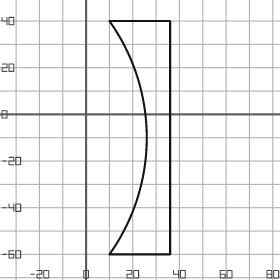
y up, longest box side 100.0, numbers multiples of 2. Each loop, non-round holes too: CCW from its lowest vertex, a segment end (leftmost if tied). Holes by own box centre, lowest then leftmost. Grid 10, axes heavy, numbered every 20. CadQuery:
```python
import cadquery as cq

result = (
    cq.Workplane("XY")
    .moveTo(10.0, -60.0)
    .lineTo(36.0, -60.0)
    .lineTo(36.0, 40.0)
    .lineTo(10.0, 40.0)
    .threePointArc((26.0, -10.0), (10.0, -60.0))
    .close()
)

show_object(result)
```